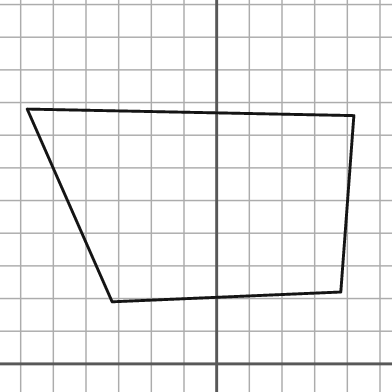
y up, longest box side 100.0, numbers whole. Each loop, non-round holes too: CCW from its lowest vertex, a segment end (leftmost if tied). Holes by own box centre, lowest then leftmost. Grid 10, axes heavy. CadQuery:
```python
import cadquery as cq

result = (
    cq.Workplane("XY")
    .moveTo(-32.0, 19.0)
    .lineTo(38.0, 22.0)
    .lineTo(42.0, 76.0)
    .lineTo(-58.0, 78.0)
    .close()
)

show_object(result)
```